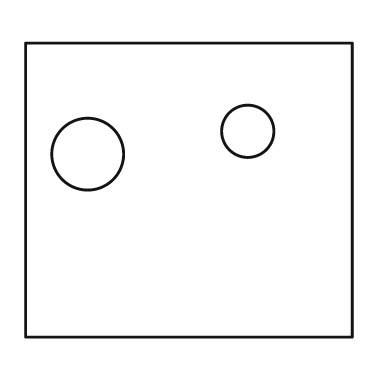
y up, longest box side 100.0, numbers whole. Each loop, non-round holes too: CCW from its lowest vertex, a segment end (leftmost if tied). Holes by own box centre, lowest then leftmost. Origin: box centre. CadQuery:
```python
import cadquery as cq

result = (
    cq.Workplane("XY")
    .moveTo(-50.0, -45.0)
    .lineTo(50.0, -45.0)
    .lineTo(50.0, 45.0)
    .lineTo(-50.0, 45.0)
    .close()
    .moveTo(-31.0, 11.0)
    .circle(11.0)
    .moveTo(18.0, 18.0)
    .circle(8.0)
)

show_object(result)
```